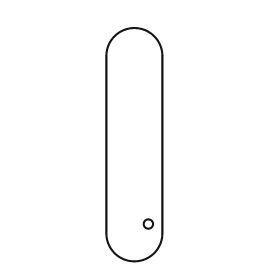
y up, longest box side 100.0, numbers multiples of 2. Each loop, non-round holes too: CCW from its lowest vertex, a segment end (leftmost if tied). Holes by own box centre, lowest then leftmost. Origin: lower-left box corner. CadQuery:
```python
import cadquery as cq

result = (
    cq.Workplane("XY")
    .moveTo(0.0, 12.0)
    .threePointArc((12.0, 0.0), (24.0, 12.0))
    .lineTo(24.0, 88.0)
    .threePointArc((12.0, 100.0), (0.0, 88.0))
    .close()
    .moveTo(18.0, 16.0)
    .circle(2.0)
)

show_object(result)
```